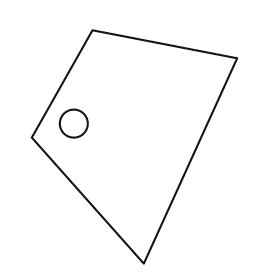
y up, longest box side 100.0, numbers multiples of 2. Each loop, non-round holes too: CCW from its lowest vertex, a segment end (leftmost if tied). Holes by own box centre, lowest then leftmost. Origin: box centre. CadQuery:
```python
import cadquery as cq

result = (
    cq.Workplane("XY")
    .moveTo(4.0, -50.0)
    .lineTo(44.0, 38.0)
    .lineTo(-18.0, 50.0)
    .lineTo(-44.0, 4.0)
    .close()
    .moveTo(-26.0, 10.0)
    .circle(6.0)
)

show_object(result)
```